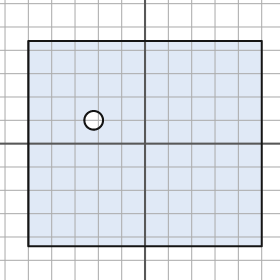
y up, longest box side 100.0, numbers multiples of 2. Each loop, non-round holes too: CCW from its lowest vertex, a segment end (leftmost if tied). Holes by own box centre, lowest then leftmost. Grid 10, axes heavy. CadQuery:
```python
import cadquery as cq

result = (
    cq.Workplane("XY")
    .moveTo(-50.0, -44.0)
    .lineTo(50.0, -44.0)
    .lineTo(50.0, 44.0)
    .lineTo(-50.0, 44.0)
    .close()
    .moveTo(-22.0, 10.0)
    .circle(4.0)
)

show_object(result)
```